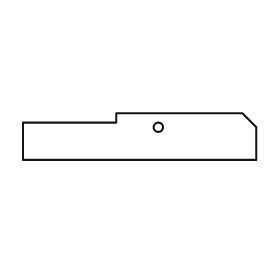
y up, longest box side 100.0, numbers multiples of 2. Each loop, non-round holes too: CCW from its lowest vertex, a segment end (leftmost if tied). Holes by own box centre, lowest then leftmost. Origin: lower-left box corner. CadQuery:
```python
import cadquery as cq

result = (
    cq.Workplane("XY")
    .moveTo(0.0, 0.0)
    .lineTo(100.0, 0.0)
    .lineTo(100.0, 14.0)
    .lineTo(94.0, 20.0)
    .lineTo(40.0, 20.0)
    .lineTo(40.0, 16.0)
    .lineTo(0.0, 16.0)
    .close()
    .moveTo(58.0, 14.0)
    .circle(2.0)
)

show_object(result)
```